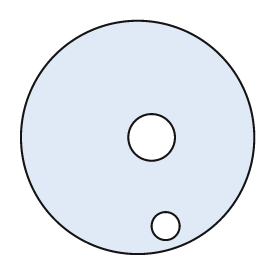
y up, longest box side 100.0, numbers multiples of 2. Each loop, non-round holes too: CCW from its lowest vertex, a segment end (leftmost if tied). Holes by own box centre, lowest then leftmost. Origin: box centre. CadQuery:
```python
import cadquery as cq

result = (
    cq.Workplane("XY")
    .moveTo(0.0, 0.0)
    .circle(50.0)
    .moveTo(12.0, -38.0)
    .circle(6.0)
    .moveTo(6.0, 0.0)
    .circle(10.0)
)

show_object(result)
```